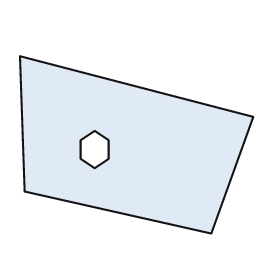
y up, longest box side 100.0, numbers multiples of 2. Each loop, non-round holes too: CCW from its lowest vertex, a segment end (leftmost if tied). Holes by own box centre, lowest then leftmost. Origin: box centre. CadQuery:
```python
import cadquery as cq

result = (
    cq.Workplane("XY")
    .moveTo(32.0, -38.0)
    .lineTo(50.0, 12.0)
    .lineTo(-50.0, 38.0)
    .lineTo(-48.0, -20.0)
    .close()
    .moveTo(-18.0, -10.0)
    .lineTo(-12.0, -6.0)
    .lineTo(-12.0, 2.0)
    .lineTo(-18.0, 6.0)
    .lineTo(-24.0, 2.0)
    .lineTo(-24.0, -6.0)
    .close()
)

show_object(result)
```